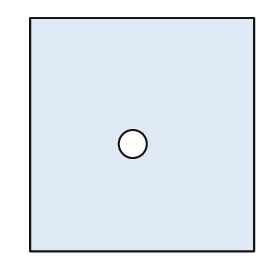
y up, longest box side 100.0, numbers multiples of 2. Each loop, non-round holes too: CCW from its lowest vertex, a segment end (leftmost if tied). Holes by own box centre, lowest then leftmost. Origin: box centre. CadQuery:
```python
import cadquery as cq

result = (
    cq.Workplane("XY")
    .moveTo(-48.0, -50.0)
    .lineTo(48.0, -50.0)
    .lineTo(48.0, 50.0)
    .lineTo(-48.0, 50.0)
    .close()
    .moveTo(-4.0, -4.0)
    .circle(6.0)
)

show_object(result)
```